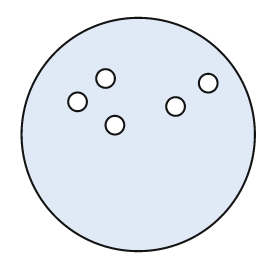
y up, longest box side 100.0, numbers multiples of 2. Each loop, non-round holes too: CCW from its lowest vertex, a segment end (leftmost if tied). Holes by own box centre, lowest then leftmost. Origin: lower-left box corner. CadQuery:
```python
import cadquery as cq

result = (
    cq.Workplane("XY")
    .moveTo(50.0, 50.0)
    .circle(50.0)
    .moveTo(40.0, 54.0)
    .circle(4.0)
    .moveTo(66.0, 62.0)
    .circle(4.0)
    .moveTo(24.0, 64.0)
    .circle(4.0)
    .moveTo(80.0, 72.0)
    .circle(4.0)
    .moveTo(36.0, 74.0)
    .circle(4.0)
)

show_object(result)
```